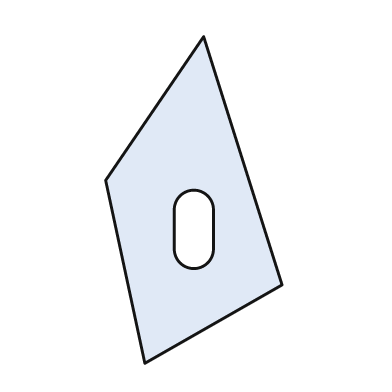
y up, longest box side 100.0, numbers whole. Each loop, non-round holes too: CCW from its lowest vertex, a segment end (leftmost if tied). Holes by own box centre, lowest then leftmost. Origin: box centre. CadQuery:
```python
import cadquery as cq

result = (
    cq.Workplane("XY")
    .moveTo(-15.0, -50.0)
    .lineTo(27.0, -26.0)
    .lineTo(3.0, 50.0)
    .lineTo(-27.0, 6.0)
    .close()
    .moveTo(-6.0, -15.0)
    .threePointArc((0.0, -21.0), (6.0, -15.0))
    .lineTo(6.0, -3.0)
    .threePointArc((0.0, 3.0), (-6.0, -3.0))
    .close()
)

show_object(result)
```